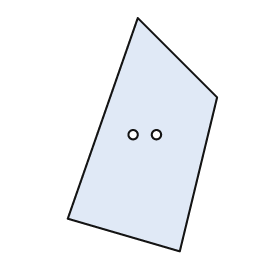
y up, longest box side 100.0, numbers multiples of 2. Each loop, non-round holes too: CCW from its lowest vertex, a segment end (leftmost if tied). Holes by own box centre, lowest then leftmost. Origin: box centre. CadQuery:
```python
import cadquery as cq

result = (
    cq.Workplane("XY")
    .moveTo(16.0, -50.0)
    .lineTo(32.0, 16.0)
    .lineTo(-2.0, 50.0)
    .lineTo(-32.0, -36.0)
    .close()
    .moveTo(-4.0, 0.0)
    .circle(2.0)
    .moveTo(6.0, 0.0)
    .circle(2.0)
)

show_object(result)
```